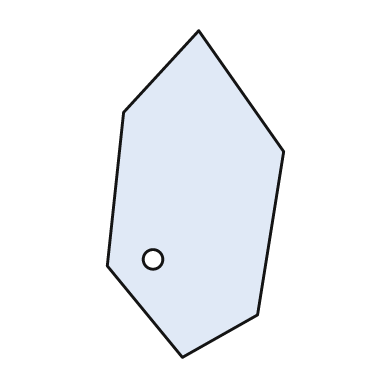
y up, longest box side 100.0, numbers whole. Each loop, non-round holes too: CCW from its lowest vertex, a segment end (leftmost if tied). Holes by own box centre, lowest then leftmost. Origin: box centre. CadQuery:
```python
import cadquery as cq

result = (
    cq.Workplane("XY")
    .moveTo(-4.0, -50.0)
    .lineTo(19.0, -37.0)
    .lineTo(27.0, 13.0)
    .lineTo(1.0, 50.0)
    .lineTo(-22.0, 25.0)
    .lineTo(-27.0, -22.0)
    .close()
    .moveTo(-13.0, -20.0)
    .circle(3.0)
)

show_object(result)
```